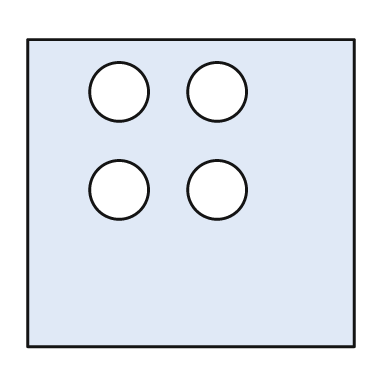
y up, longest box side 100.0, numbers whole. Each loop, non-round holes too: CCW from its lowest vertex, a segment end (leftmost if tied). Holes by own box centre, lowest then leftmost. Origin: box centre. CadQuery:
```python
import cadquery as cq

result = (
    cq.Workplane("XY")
    .moveTo(-50.0, -47.0)
    .lineTo(50.0, -47.0)
    .lineTo(50.0, 47.0)
    .lineTo(-50.0, 47.0)
    .close()
    .moveTo(-22.0, 1.0)
    .circle(9.0)
    .moveTo(8.0, 1.0)
    .circle(9.0)
    .moveTo(-22.0, 31.0)
    .circle(9.0)
    .moveTo(8.0, 31.0)
    .circle(9.0)
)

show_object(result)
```